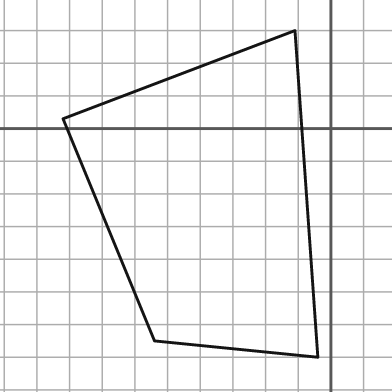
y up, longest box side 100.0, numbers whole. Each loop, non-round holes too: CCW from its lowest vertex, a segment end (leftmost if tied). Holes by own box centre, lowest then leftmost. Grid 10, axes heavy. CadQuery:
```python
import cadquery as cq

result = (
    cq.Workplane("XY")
    .moveTo(-4.0, -70.0)
    .lineTo(-11.0, 30.0)
    .lineTo(-82.0, 3.0)
    .lineTo(-54.0, -65.0)
    .close()
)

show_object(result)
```